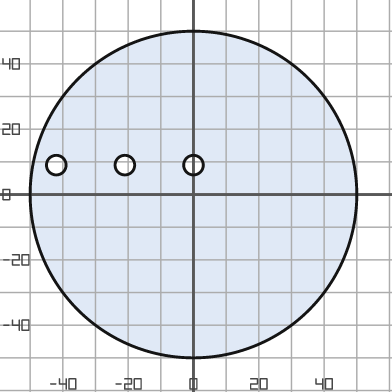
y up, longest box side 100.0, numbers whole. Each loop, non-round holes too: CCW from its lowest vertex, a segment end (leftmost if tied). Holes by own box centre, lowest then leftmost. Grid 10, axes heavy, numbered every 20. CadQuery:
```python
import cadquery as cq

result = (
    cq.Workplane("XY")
    .moveTo(0.0, 0.0)
    .circle(50.0)
    .moveTo(-42.0, 9.0)
    .circle(3.0)
    .moveTo(-21.0, 9.0)
    .circle(3.0)
    .moveTo(0.0, 9.0)
    .circle(3.0)
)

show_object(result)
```